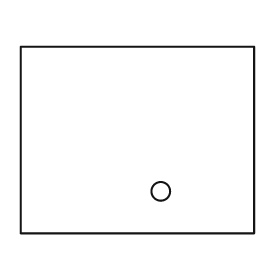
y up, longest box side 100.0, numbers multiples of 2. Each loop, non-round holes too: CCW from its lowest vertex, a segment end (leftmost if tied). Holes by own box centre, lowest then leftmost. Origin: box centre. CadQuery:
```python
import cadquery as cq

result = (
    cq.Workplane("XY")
    .moveTo(-50.0, -40.0)
    .lineTo(50.0, -40.0)
    .lineTo(50.0, 40.0)
    .lineTo(-50.0, 40.0)
    .close()
    .moveTo(10.0, -22.0)
    .circle(4.0)
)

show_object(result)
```